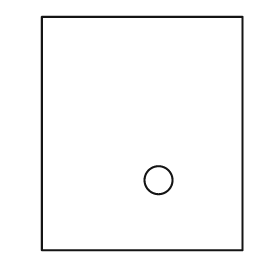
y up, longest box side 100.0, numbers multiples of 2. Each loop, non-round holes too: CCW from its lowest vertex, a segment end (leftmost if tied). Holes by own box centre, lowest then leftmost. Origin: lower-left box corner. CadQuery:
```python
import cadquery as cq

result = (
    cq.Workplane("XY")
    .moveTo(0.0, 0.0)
    .lineTo(86.0, 0.0)
    .lineTo(86.0, 100.0)
    .lineTo(0.0, 100.0)
    .close()
    .moveTo(50.0, 30.0)
    .circle(6.0)
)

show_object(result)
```